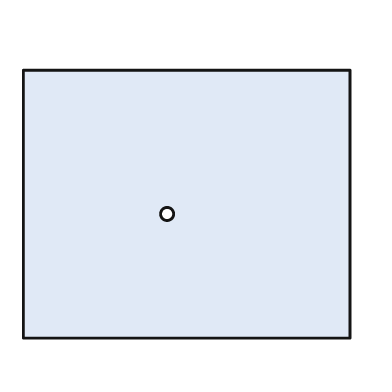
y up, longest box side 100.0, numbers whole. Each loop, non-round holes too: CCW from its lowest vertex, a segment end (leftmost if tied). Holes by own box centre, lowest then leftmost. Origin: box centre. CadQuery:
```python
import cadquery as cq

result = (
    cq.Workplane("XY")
    .moveTo(-50.0, -41.0)
    .lineTo(50.0, -41.0)
    .lineTo(50.0, 41.0)
    .lineTo(-50.0, 41.0)
    .close()
    .moveTo(-6.0, -3.0)
    .circle(2.0)
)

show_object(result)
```